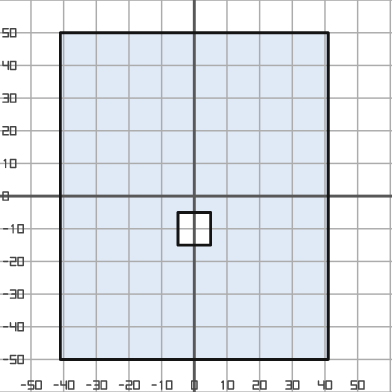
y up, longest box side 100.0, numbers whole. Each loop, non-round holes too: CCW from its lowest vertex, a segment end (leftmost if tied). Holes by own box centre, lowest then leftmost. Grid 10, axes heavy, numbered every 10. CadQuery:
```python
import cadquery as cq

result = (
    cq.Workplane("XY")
    .moveTo(-41.0, -50.0)
    .lineTo(41.0, -50.0)
    .lineTo(41.0, 50.0)
    .lineTo(-41.0, 50.0)
    .close()
    .moveTo(-5.0, -15.0)
    .lineTo(5.0, -15.0)
    .lineTo(5.0, -5.0)
    .lineTo(-5.0, -5.0)
    .close()
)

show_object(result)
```